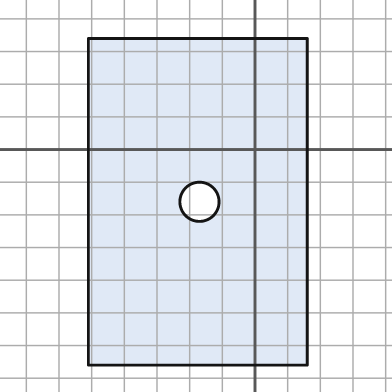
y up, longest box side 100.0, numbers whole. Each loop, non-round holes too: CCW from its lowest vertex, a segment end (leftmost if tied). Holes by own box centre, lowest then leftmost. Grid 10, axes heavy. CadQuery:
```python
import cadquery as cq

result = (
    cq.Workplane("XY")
    .moveTo(-51.0, -66.0)
    .lineTo(16.0, -66.0)
    .lineTo(16.0, 34.0)
    .lineTo(-51.0, 34.0)
    .close()
    .moveTo(-17.0, -16.0)
    .circle(6.0)
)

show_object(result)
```